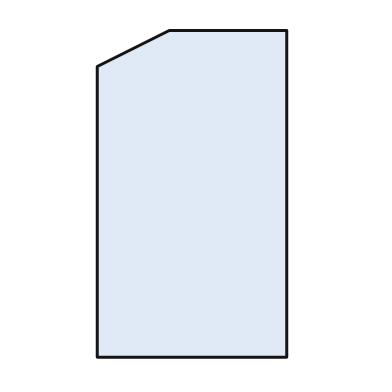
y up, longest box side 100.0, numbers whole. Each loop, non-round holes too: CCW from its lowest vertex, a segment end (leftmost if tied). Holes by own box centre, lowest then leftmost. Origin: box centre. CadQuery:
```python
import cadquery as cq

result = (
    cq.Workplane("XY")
    .moveTo(-29.0, -50.0)
    .lineTo(29.0, -50.0)
    .lineTo(29.0, 50.0)
    .lineTo(-7.0, 50.0)
    .lineTo(-29.0, 39.0)
    .close()
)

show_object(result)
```